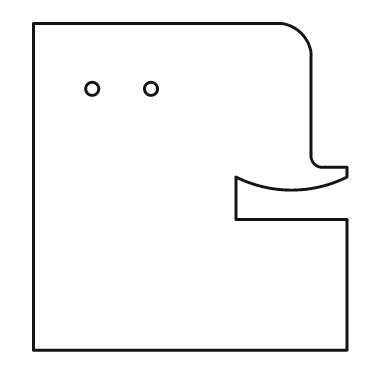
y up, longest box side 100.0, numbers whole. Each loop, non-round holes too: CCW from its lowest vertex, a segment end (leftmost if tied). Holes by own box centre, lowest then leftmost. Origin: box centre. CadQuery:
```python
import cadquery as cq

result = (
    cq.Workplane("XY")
    .moveTo(-48.0, -50.0)
    .lineTo(48.0, -50.0)
    .lineTo(48.0, -10.0)
    .lineTo(14.0, -10.0)
    .lineTo(14.0, 3.0)
    .threePointArc((31.0, -1.0), (48.0, 3.0))
    .lineTo(48.0, 6.0)
    .lineTo(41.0, 6.0)
    .threePointArc((38.0, 7.0), (37.0, 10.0))
    .lineTo(37.0, 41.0)
    .threePointArc((34.0, 47.0), (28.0, 50.0))
    .lineTo(-48.0, 50.0)
    .close()
    .moveTo(-30.0, 30.0)
    .circle(2.0)
    .moveTo(-12.0, 30.0)
    .circle(2.0)
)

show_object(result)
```